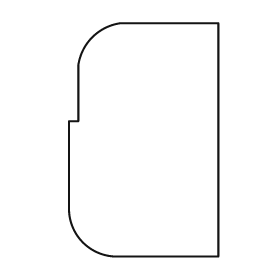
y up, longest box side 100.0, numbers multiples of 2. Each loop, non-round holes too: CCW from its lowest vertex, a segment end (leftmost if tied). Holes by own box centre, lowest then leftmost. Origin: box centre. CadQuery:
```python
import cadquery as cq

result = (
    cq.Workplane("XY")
    .moveTo(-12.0, -50.0)
    .lineTo(32.0, -50.0)
    .lineTo(32.0, 50.0)
    .lineTo(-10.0, 50.0)
    .threePointArc((-22.0, 44.0), (-28.0, 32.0))
    .lineTo(-28.0, 8.0)
    .lineTo(-32.0, 8.0)
    .lineTo(-32.0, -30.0)
    .threePointArc((-26.0, -44.0), (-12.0, -50.0))
    .close()
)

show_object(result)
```